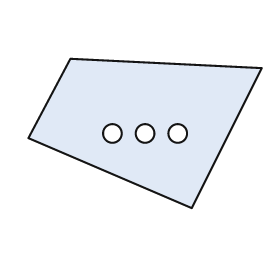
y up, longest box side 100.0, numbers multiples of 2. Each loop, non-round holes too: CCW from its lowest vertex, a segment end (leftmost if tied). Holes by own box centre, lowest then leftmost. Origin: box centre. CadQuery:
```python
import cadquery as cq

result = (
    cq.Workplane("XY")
    .moveTo(20.0, -32.0)
    .lineTo(50.0, 28.0)
    .lineTo(-32.0, 32.0)
    .lineTo(-50.0, -2.0)
    .close()
    .moveTo(-14.0, 0.0)
    .circle(4.0)
    .moveTo(0.0, 0.0)
    .circle(4.0)
    .moveTo(14.0, 0.0)
    .circle(4.0)
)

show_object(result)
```